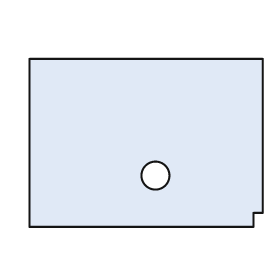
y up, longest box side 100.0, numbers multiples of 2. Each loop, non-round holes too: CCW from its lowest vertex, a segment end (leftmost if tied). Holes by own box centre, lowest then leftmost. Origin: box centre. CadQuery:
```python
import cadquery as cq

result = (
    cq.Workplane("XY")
    .moveTo(-50.0, -36.0)
    .lineTo(46.0, -36.0)
    .lineTo(46.0, -30.0)
    .lineTo(50.0, -30.0)
    .lineTo(50.0, 36.0)
    .lineTo(-50.0, 36.0)
    .close()
    .moveTo(4.0, -14.0)
    .circle(6.0)
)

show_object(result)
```